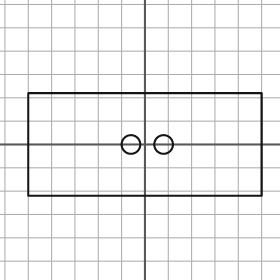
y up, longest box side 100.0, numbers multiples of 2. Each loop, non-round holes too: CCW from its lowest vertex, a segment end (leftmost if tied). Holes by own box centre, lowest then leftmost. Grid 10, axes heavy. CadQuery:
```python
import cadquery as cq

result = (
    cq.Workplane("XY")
    .moveTo(-50.0, -22.0)
    .lineTo(50.0, -22.0)
    .lineTo(50.0, 22.0)
    .lineTo(-50.0, 22.0)
    .close()
    .moveTo(-6.0, 0.0)
    .circle(4.0)
    .moveTo(8.0, 0.0)
    .circle(4.0)
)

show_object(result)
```